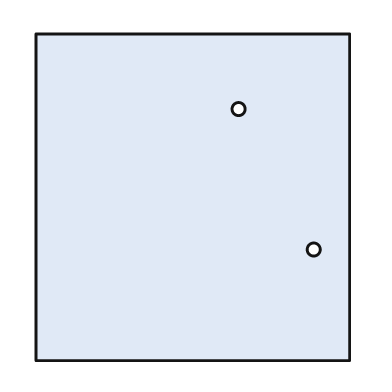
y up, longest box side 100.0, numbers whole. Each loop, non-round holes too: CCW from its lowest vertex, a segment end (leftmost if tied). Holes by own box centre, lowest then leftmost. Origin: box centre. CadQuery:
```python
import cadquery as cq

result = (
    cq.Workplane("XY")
    .moveTo(-48.0, -50.0)
    .lineTo(48.0, -50.0)
    .lineTo(48.0, 50.0)
    .lineTo(-48.0, 50.0)
    .close()
    .moveTo(37.0, -16.0)
    .circle(2.0)
    .moveTo(14.0, 27.0)
    .circle(2.0)
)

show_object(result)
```